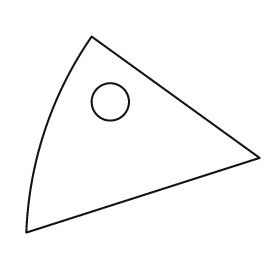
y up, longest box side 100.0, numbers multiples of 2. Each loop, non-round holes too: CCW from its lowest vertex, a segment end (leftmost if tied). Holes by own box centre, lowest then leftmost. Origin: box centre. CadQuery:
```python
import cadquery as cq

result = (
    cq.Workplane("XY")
    .moveTo(-50.0, -42.0)
    .lineTo(50.0, -10.0)
    .lineTo(-22.0, 42.0)
    .threePointArc((-42.0, 2.0), (-50.0, -42.0))
    .close()
    .moveTo(-14.0, 14.0)
    .circle(8.0)
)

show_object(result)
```